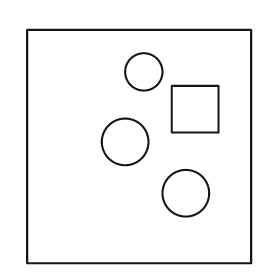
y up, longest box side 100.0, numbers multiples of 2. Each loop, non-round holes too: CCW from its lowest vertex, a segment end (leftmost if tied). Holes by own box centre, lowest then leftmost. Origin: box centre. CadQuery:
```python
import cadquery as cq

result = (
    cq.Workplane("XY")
    .moveTo(-48.0, -50.0)
    .lineTo(48.0, -50.0)
    .lineTo(48.0, 50.0)
    .lineTo(-48.0, 50.0)
    .close()
    .moveTo(20.0, -20.0)
    .circle(10.0)
    .moveTo(-6.0, 2.0)
    .circle(10.0)
    .moveTo(14.0, 6.0)
    .lineTo(34.0, 6.0)
    .lineTo(34.0, 26.0)
    .lineTo(14.0, 26.0)
    .close()
    .moveTo(2.0, 32.0)
    .circle(8.0)
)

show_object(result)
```